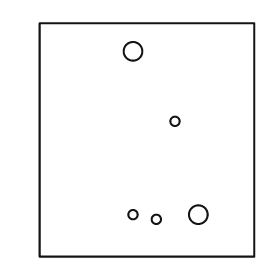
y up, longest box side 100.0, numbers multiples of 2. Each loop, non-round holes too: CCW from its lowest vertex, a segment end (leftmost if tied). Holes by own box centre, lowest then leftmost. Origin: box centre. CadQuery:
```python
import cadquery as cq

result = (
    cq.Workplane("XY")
    .moveTo(-46.0, -50.0)
    .lineTo(46.0, -50.0)
    .lineTo(46.0, 50.0)
    .lineTo(-46.0, 50.0)
    .close()
    .moveTo(4.0, -34.0)
    .circle(2.0)
    .moveTo(-6.0, -32.0)
    .circle(2.0)
    .moveTo(22.0, -32.0)
    .circle(4.0)
    .moveTo(12.0, 8.0)
    .circle(2.0)
    .moveTo(-6.0, 38.0)
    .circle(4.0)
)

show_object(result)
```